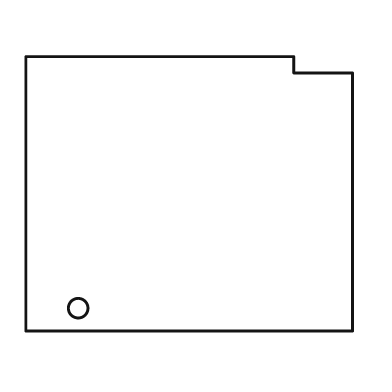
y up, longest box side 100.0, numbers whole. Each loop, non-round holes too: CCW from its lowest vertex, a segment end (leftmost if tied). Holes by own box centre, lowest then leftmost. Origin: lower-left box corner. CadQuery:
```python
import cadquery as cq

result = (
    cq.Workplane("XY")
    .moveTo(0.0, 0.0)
    .lineTo(100.0, 0.0)
    .lineTo(100.0, 79.0)
    .lineTo(82.0, 79.0)
    .lineTo(82.0, 84.0)
    .lineTo(0.0, 84.0)
    .close()
    .moveTo(16.0, 7.0)
    .circle(3.0)
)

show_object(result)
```